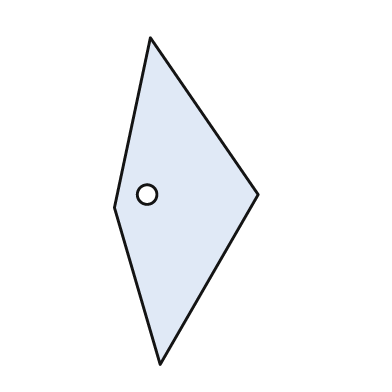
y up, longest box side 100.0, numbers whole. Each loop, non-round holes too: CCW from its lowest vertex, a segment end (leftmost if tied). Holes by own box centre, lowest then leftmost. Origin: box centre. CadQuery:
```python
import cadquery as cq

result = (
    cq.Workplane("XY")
    .moveTo(-8.0, -50.0)
    .lineTo(22.0, 2.0)
    .lineTo(-11.0, 50.0)
    .lineTo(-22.0, -2.0)
    .close()
    .moveTo(-12.0, 2.0)
    .circle(3.0)
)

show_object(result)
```